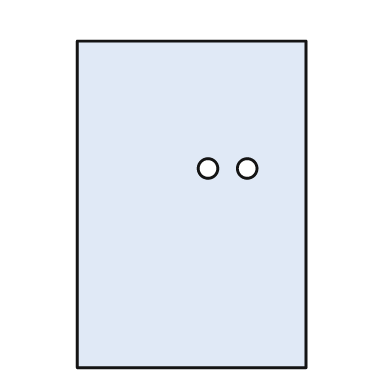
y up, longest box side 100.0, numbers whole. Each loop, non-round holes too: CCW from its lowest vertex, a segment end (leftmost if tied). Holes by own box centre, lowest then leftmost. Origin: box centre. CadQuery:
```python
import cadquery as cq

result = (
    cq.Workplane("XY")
    .moveTo(-35.0, -50.0)
    .lineTo(35.0, -50.0)
    .lineTo(35.0, 50.0)
    .lineTo(-35.0, 50.0)
    .close()
    .moveTo(5.0, 11.0)
    .circle(3.0)
    .moveTo(17.0, 11.0)
    .circle(3.0)
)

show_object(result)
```